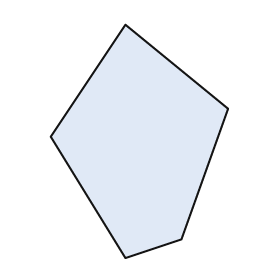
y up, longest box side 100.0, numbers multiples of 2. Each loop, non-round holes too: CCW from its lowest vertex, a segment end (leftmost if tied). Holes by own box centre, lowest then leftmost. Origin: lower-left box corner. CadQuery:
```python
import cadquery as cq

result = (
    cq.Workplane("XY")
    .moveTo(32.0, 0.0)
    .lineTo(56.0, 8.0)
    .lineTo(76.0, 64.0)
    .lineTo(32.0, 100.0)
    .lineTo(0.0, 52.0)
    .close()
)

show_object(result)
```